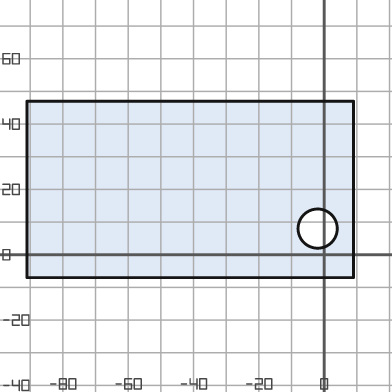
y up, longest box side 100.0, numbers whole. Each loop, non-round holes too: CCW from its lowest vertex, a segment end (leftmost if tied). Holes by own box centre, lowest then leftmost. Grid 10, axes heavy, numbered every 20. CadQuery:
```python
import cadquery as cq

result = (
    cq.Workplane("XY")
    .moveTo(-91.0, -7.0)
    .lineTo(9.0, -7.0)
    .lineTo(9.0, 47.0)
    .lineTo(-91.0, 47.0)
    .close()
    .moveTo(-2.0, 8.0)
    .circle(6.0)
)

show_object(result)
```